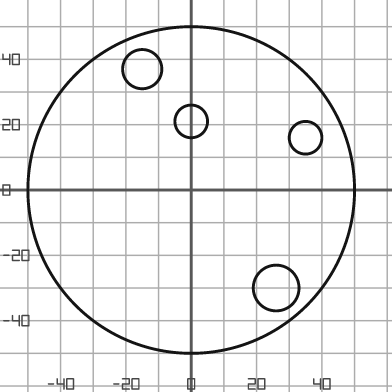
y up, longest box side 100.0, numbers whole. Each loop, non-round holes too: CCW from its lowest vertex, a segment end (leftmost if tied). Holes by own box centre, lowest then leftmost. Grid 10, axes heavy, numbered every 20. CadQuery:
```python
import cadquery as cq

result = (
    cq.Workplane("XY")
    .moveTo(0.0, 0.0)
    .circle(50.0)
    .moveTo(26.0, -30.0)
    .circle(7.0)
    .moveTo(35.0, 16.0)
    .circle(5.0)
    .moveTo(0.0, 21.0)
    .circle(5.0)
    .moveTo(-15.0, 37.0)
    .circle(6.0)
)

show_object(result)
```